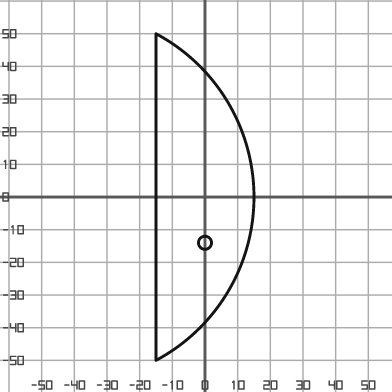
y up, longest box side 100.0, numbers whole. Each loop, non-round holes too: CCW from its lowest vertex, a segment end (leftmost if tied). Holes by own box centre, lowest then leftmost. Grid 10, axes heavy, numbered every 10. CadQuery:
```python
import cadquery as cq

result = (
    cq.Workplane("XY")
    .moveTo(-15.0, -50.0)
    .threePointArc((15.0, 0.0), (-15.0, 50.0))
    .close()
    .moveTo(0.0, -14.0)
    .circle(2.0)
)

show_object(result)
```